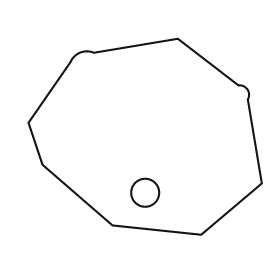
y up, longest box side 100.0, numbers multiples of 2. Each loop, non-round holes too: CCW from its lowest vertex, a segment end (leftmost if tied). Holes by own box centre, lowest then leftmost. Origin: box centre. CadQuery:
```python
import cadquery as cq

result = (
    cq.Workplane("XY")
    .moveTo(24.0, -42.0)
    .lineTo(50.0, -20.0)
    .lineTo(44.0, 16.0)
    .threePointArc((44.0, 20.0), (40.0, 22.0))
    .lineTo(14.0, 42.0)
    .lineTo(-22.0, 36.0)
    .threePointArc((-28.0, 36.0), (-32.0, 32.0))
    .lineTo(-50.0, 6.0)
    .lineTo(-44.0, -12.0)
    .lineTo(-14.0, -38.0)
    .close()
    .moveTo(0.0, -24.0)
    .circle(6.0)
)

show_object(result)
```